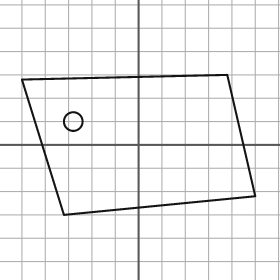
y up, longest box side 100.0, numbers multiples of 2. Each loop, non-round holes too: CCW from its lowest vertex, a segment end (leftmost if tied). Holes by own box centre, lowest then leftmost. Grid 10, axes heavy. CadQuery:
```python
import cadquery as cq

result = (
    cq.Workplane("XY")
    .moveTo(-32.0, -30.0)
    .lineTo(50.0, -22.0)
    .lineTo(38.0, 30.0)
    .lineTo(-50.0, 28.0)
    .close()
    .moveTo(-28.0, 10.0)
    .circle(4.0)
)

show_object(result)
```